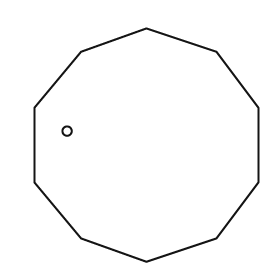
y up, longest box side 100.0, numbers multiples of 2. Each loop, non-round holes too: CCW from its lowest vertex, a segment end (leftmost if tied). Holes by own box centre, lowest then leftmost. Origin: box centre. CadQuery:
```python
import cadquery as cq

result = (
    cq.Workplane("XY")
    .moveTo(0.0, -50.0)
    .lineTo(30.0, -40.0)
    .lineTo(48.0, -16.0)
    .lineTo(48.0, 16.0)
    .lineTo(30.0, 40.0)
    .lineTo(0.0, 50.0)
    .lineTo(-28.0, 40.0)
    .lineTo(-48.0, 16.0)
    .lineTo(-48.0, -16.0)
    .lineTo(-28.0, -40.0)
    .close()
    .moveTo(-34.0, 6.0)
    .circle(2.0)
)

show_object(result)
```